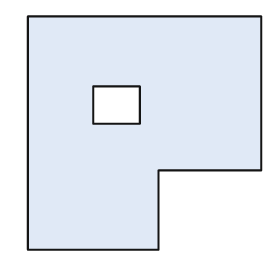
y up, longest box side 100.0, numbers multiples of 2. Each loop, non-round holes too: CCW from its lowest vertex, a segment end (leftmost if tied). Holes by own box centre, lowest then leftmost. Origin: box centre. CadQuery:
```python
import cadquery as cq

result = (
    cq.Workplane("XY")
    .moveTo(-50.0, -50.0)
    .lineTo(6.0, -50.0)
    .lineTo(6.0, -16.0)
    .lineTo(50.0, -16.0)
    .lineTo(50.0, 50.0)
    .lineTo(-50.0, 50.0)
    .close()
    .moveTo(-22.0, 4.0)
    .lineTo(-2.0, 4.0)
    .lineTo(-2.0, 20.0)
    .lineTo(-22.0, 20.0)
    .close()
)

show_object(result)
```